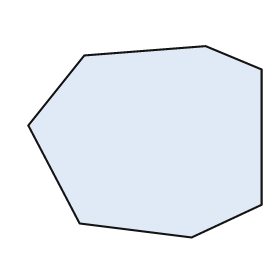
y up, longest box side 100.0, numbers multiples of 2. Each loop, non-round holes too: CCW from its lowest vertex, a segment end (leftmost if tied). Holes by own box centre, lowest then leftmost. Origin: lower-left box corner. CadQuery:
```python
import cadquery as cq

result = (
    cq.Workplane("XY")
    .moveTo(70.0, 0.0)
    .lineTo(100.0, 14.0)
    .lineTo(100.0, 72.0)
    .lineTo(76.0, 82.0)
    .lineTo(24.0, 78.0)
    .lineTo(0.0, 48.0)
    .lineTo(22.0, 6.0)
    .close()
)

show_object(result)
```